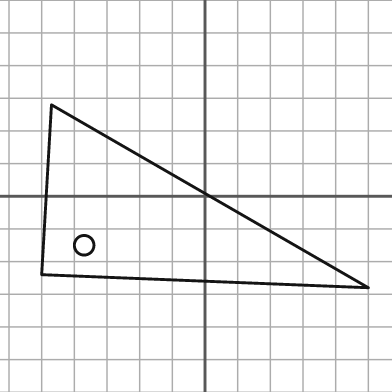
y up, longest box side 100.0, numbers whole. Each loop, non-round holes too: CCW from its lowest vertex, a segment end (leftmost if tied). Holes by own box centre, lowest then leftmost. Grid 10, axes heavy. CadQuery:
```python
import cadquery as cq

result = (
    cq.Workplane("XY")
    .moveTo(50.0, -28.0)
    .lineTo(-47.0, 28.0)
    .lineTo(-50.0, -24.0)
    .close()
    .moveTo(-37.0, -15.0)
    .circle(3.0)
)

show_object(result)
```